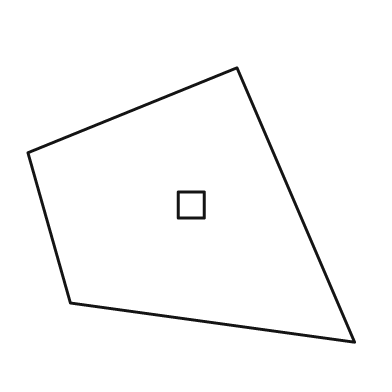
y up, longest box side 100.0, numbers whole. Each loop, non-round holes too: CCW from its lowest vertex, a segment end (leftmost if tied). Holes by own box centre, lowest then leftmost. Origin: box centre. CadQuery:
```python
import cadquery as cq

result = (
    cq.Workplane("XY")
    .moveTo(50.0, -42.0)
    .lineTo(14.0, 42.0)
    .lineTo(-50.0, 16.0)
    .lineTo(-37.0, -30.0)
    .close()
    .moveTo(-4.0, -4.0)
    .lineTo(4.0, -4.0)
    .lineTo(4.0, 4.0)
    .lineTo(-4.0, 4.0)
    .close()
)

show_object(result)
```